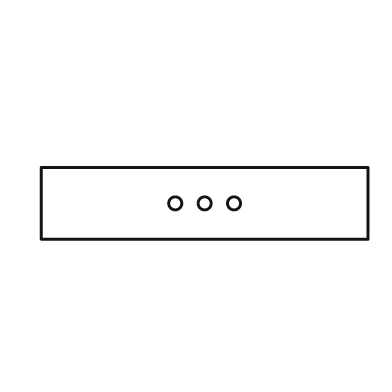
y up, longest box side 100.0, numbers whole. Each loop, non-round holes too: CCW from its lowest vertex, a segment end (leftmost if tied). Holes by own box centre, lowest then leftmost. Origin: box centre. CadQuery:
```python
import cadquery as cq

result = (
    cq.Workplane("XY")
    .moveTo(-50.0, -11.0)
    .lineTo(50.0, -11.0)
    .lineTo(50.0, 11.0)
    .lineTo(-50.0, 11.0)
    .close()
    .moveTo(-9.0, 0.0)
    .circle(2.0)
    .moveTo(0.0, 0.0)
    .circle(2.0)
    .moveTo(9.0, 0.0)
    .circle(2.0)
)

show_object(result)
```